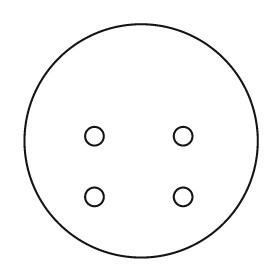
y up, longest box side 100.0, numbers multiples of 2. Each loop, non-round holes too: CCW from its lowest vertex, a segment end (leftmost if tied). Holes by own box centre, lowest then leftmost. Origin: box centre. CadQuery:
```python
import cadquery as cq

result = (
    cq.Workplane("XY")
    .moveTo(0.0, 0.0)
    .circle(50.0)
    .moveTo(-20.0, -24.0)
    .circle(4.0)
    .moveTo(18.0, -24.0)
    .circle(4.0)
    .moveTo(-20.0, 2.0)
    .circle(4.0)
    .moveTo(18.0, 2.0)
    .circle(4.0)
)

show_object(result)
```